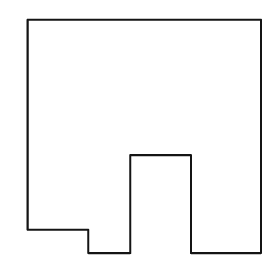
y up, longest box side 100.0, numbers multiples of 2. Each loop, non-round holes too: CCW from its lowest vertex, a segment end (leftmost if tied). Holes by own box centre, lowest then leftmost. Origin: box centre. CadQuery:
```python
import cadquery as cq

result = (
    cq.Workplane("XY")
    .moveTo(-24.0, -50.0)
    .lineTo(-6.0, -50.0)
    .lineTo(-6.0, -8.0)
    .lineTo(20.0, -8.0)
    .lineTo(20.0, -50.0)
    .lineTo(50.0, -50.0)
    .lineTo(50.0, 50.0)
    .lineTo(-50.0, 50.0)
    .lineTo(-50.0, -40.0)
    .lineTo(-24.0, -40.0)
    .close()
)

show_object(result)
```